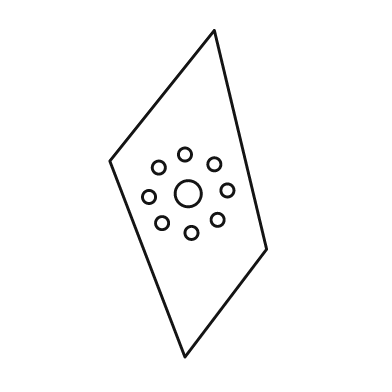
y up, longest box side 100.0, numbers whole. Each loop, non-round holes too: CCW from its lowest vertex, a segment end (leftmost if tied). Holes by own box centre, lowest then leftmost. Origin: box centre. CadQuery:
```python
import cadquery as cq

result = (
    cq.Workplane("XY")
    .moveTo(-1.0, -50.0)
    .lineTo(24.0, -17.0)
    .lineTo(8.0, 50.0)
    .lineTo(-24.0, 10.0)
    .close()
    .moveTo(1.0, -12.0)
    .circle(2.0)
    .moveTo(-8.0, -9.0)
    .circle(2.0)
    .moveTo(9.0, -8.0)
    .circle(2.0)
    .moveTo(-12.0, -1.0)
    .circle(2.0)
    .moveTo(0.0, 0.0)
    .circle(4.0)
    .moveTo(12.0, 1.0)
    .circle(2.0)
    .moveTo(-9.0, 8.0)
    .circle(2.0)
    .moveTo(8.0, 9.0)
    .circle(2.0)
    .moveTo(-1.0, 12.0)
    .circle(2.0)
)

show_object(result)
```